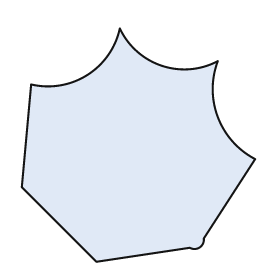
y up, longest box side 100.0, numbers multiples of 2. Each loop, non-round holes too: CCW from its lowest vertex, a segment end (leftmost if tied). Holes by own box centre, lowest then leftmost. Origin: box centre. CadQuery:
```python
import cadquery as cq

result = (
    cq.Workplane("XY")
    .moveTo(-18.0, -50.0)
    .lineTo(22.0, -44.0)
    .threePointArc((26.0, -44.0), (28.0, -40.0))
    .lineTo(50.0, -6.0)
    .threePointArc((34.0, 12.0), (34.0, 36.0))
    .threePointArc((10.0, 34.0), (-8.0, 50.0))
    .threePointArc((-22.0, 30.0), (-46.0, 26.0))
    .lineTo(-50.0, -18.0)
    .close()
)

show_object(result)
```